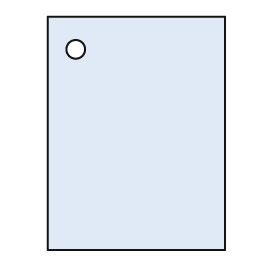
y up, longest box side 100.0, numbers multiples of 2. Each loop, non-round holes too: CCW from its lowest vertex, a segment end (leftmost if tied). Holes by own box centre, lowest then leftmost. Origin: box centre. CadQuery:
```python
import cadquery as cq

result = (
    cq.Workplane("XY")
    .moveTo(-38.0, -50.0)
    .lineTo(38.0, -50.0)
    .lineTo(38.0, 50.0)
    .lineTo(-38.0, 50.0)
    .close()
    .moveTo(-26.0, 36.0)
    .circle(4.0)
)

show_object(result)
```